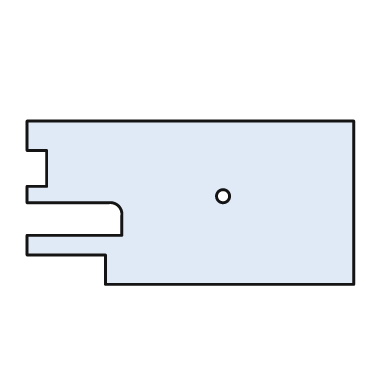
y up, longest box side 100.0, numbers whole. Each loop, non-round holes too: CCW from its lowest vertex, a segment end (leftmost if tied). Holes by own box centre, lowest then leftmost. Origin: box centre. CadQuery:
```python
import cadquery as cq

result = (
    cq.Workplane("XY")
    .moveTo(-26.0, -25.0)
    .lineTo(50.0, -25.0)
    .lineTo(50.0, 25.0)
    .lineTo(-50.0, 25.0)
    .lineTo(-50.0, 16.0)
    .lineTo(-44.0, 16.0)
    .lineTo(-44.0, 5.0)
    .lineTo(-50.0, 5.0)
    .lineTo(-50.0, 0.0)
    .lineTo(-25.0, 0.0)
    .threePointArc((-22.0, -1.0), (-21.0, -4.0))
    .lineTo(-21.0, -10.0)
    .lineTo(-50.0, -10.0)
    .lineTo(-50.0, -16.0)
    .lineTo(-26.0, -16.0)
    .close()
    .moveTo(10.0, 2.0)
    .circle(2.0)
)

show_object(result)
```